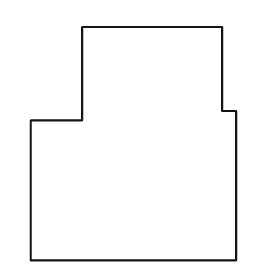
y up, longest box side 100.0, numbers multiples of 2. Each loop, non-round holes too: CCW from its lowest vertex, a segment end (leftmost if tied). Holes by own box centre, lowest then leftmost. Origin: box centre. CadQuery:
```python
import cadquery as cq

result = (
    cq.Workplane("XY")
    .moveTo(-44.0, -50.0)
    .lineTo(44.0, -50.0)
    .lineTo(44.0, 14.0)
    .lineTo(38.0, 14.0)
    .lineTo(38.0, 50.0)
    .lineTo(-22.0, 50.0)
    .lineTo(-22.0, 10.0)
    .lineTo(-44.0, 10.0)
    .close()
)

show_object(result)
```